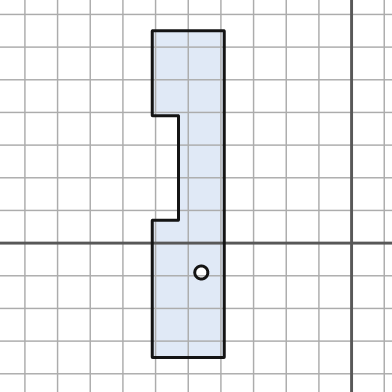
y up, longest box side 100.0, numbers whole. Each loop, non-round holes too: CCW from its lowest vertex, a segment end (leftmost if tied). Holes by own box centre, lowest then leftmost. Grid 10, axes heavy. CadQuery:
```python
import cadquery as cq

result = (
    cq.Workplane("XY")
    .moveTo(-61.0, -35.0)
    .lineTo(-39.0, -35.0)
    .lineTo(-39.0, 65.0)
    .lineTo(-61.0, 65.0)
    .lineTo(-61.0, 39.0)
    .lineTo(-53.0, 39.0)
    .lineTo(-53.0, 7.0)
    .lineTo(-61.0, 7.0)
    .close()
    .moveTo(-46.0, -9.0)
    .circle(2.0)
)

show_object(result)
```